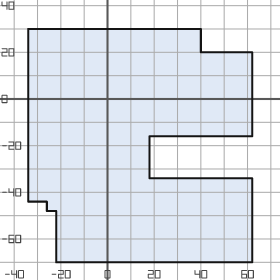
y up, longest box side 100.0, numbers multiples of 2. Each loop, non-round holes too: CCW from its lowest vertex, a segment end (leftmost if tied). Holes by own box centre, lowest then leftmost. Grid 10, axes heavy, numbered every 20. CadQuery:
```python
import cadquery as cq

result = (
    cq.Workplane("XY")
    .moveTo(-22.0, -70.0)
    .lineTo(62.0, -70.0)
    .lineTo(62.0, -34.0)
    .lineTo(18.0, -34.0)
    .lineTo(18.0, -16.0)
    .lineTo(62.0, -16.0)
    .lineTo(62.0, 20.0)
    .lineTo(40.0, 20.0)
    .lineTo(40.0, 30.0)
    .lineTo(-34.0, 30.0)
    .lineTo(-34.0, -44.0)
    .lineTo(-26.0, -44.0)
    .lineTo(-26.0, -48.0)
    .lineTo(-22.0, -48.0)
    .close()
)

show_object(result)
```